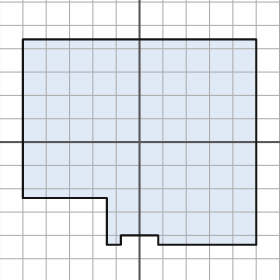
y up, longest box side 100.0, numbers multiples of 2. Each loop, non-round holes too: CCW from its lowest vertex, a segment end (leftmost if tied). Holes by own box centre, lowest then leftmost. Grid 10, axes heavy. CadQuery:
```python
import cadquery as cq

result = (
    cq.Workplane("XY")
    .moveTo(-14.0, -44.0)
    .lineTo(-8.0, -44.0)
    .lineTo(-8.0, -40.0)
    .lineTo(8.0, -40.0)
    .lineTo(8.0, -44.0)
    .lineTo(50.0, -44.0)
    .lineTo(50.0, 44.0)
    .lineTo(-50.0, 44.0)
    .lineTo(-50.0, -24.0)
    .lineTo(-14.0, -24.0)
    .close()
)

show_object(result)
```